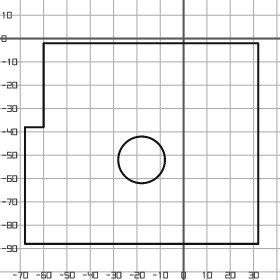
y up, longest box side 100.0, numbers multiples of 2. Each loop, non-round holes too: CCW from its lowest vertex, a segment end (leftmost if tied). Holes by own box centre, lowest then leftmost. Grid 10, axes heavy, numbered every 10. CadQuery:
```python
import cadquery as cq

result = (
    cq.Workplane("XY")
    .moveTo(-68.0, -88.0)
    .lineTo(32.0, -88.0)
    .lineTo(32.0, -2.0)
    .lineTo(-60.0, -2.0)
    .lineTo(-60.0, -38.0)
    .lineTo(-68.0, -38.0)
    .close()
    .moveTo(-18.0, -52.0)
    .circle(10.0)
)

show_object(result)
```